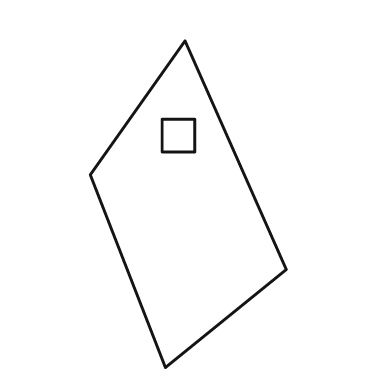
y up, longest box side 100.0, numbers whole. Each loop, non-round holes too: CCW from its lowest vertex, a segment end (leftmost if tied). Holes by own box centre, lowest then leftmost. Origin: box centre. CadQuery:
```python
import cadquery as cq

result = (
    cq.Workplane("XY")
    .moveTo(-7.0, -50.0)
    .lineTo(30.0, -20.0)
    .lineTo(-1.0, 50.0)
    .lineTo(-30.0, 9.0)
    .close()
    .moveTo(-8.0, 16.0)
    .lineTo(2.0, 16.0)
    .lineTo(2.0, 26.0)
    .lineTo(-8.0, 26.0)
    .close()
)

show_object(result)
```